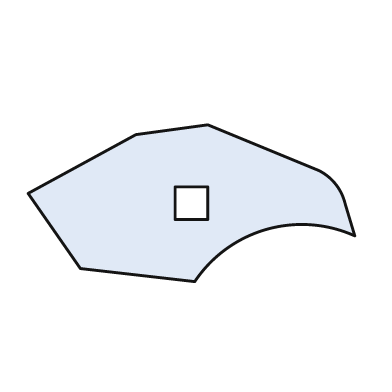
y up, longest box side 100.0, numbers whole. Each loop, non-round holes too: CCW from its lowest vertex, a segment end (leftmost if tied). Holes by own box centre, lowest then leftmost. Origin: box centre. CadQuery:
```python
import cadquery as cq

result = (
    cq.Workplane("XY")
    .moveTo(1.0, -24.0)
    .threePointArc((23.0, -8.0), (50.0, -10.0))
    .lineTo(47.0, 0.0)
    .threePointArc((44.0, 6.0), (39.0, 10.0))
    .lineTo(5.0, 24.0)
    .lineTo(-17.0, 21.0)
    .lineTo(-50.0, 3.0)
    .lineTo(-34.0, -20.0)
    .close()
    .moveTo(-5.0, -5.0)
    .lineTo(5.0, -5.0)
    .lineTo(5.0, 5.0)
    .lineTo(-5.0, 5.0)
    .close()
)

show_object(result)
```